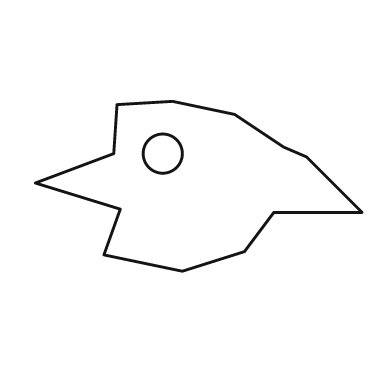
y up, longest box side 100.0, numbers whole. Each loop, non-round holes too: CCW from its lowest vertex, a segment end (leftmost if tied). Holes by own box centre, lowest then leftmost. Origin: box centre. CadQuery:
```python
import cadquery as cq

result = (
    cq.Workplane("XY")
    .moveTo(-5.0, -26.0)
    .lineTo(14.0, -20.0)
    .lineTo(23.0, -8.0)
    .lineTo(50.0, -8.0)
    .lineTo(33.0, 9.0)
    .lineTo(26.0, 12.0)
    .lineTo(11.0, 22.0)
    .lineTo(-8.0, 26.0)
    .lineTo(-25.0, 25.0)
    .lineTo(-26.0, 10.0)
    .lineTo(-50.0, 1.0)
    .lineTo(-24.0, -7.0)
    .lineTo(-29.0, -21.0)
    .close()
    .moveTo(-11.0, 10.0)
    .circle(6.0)
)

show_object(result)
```